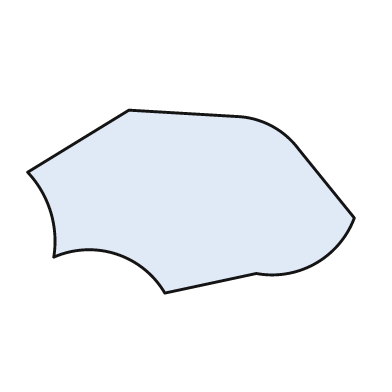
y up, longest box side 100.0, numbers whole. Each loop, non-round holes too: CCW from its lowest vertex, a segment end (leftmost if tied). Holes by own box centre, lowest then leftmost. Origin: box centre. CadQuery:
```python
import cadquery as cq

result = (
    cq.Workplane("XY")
    .moveTo(-8.0, -28.0)
    .lineTo(20.0, -22.0)
    .threePointArc((38.0, -19.0), (50.0, -5.0))
    .lineTo(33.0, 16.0)
    .threePointArc((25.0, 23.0), (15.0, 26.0))
    .lineTo(-19.0, 28.0)
    .lineTo(-50.0, 9.0)
    .threePointArc((-43.0, -3.0), (-42.0, -17.0))
    .threePointArc((-23.0, -16.0), (-8.0, -28.0))
    .close()
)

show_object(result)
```